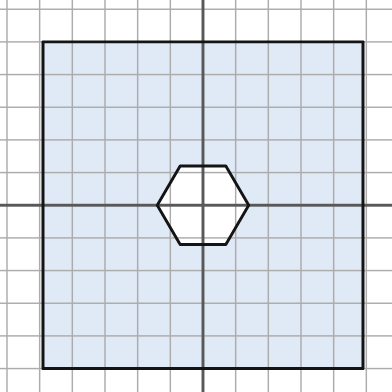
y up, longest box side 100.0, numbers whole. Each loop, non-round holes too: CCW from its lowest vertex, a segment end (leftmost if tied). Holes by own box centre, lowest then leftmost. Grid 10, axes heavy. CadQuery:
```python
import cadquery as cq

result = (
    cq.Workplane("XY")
    .moveTo(-49.0, -50.0)
    .lineTo(49.0, -50.0)
    .lineTo(49.0, 50.0)
    .lineTo(-49.0, 50.0)
    .close()
    .moveTo(-7.0, -12.0)
    .lineTo(7.0, -12.0)
    .lineTo(14.0, 0.0)
    .lineTo(7.0, 12.0)
    .lineTo(-7.0, 12.0)
    .lineTo(-14.0, 0.0)
    .close()
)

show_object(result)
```